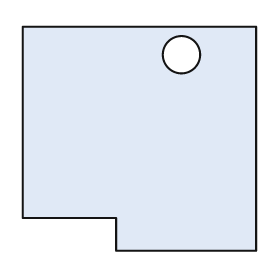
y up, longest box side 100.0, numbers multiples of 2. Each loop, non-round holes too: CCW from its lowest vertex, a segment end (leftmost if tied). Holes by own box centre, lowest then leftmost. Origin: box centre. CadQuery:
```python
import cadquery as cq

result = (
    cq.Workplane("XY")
    .moveTo(-10.0, -48.0)
    .lineTo(50.0, -48.0)
    .lineTo(50.0, 48.0)
    .lineTo(-50.0, 48.0)
    .lineTo(-50.0, -34.0)
    .lineTo(-10.0, -34.0)
    .close()
    .moveTo(18.0, 36.0)
    .circle(8.0)
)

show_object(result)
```